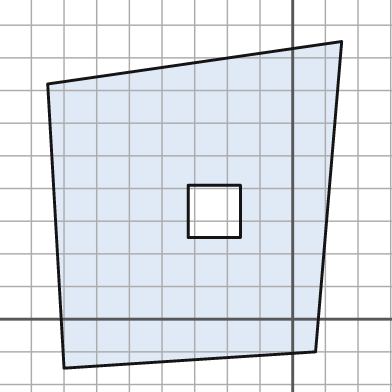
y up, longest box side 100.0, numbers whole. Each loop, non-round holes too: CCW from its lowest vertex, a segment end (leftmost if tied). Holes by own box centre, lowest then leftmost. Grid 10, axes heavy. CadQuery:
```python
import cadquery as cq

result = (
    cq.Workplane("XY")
    .moveTo(-70.0, -15.0)
    .lineTo(7.0, -10.0)
    .lineTo(15.0, 85.0)
    .lineTo(-75.0, 72.0)
    .close()
    .moveTo(-32.0, 25.0)
    .lineTo(-16.0, 25.0)
    .lineTo(-16.0, 41.0)
    .lineTo(-32.0, 41.0)
    .close()
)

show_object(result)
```